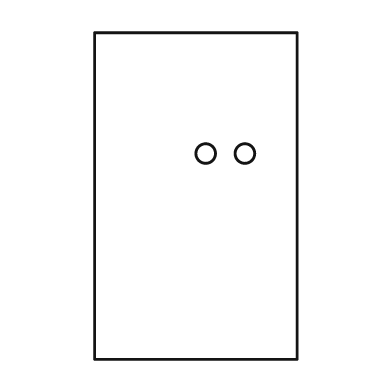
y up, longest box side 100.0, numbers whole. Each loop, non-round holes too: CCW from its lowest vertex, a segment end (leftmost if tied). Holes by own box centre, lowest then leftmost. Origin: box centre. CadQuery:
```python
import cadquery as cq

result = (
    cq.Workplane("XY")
    .moveTo(-31.0, -50.0)
    .lineTo(31.0, -50.0)
    .lineTo(31.0, 50.0)
    .lineTo(-31.0, 50.0)
    .close()
    .moveTo(3.0, 13.0)
    .circle(3.0)
    .moveTo(15.0, 13.0)
    .circle(3.0)
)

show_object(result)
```